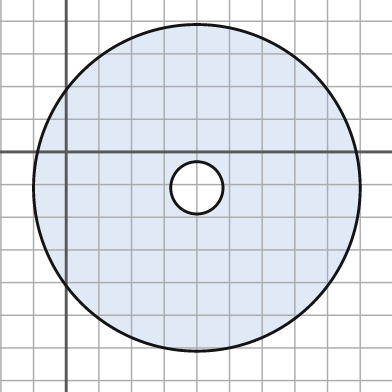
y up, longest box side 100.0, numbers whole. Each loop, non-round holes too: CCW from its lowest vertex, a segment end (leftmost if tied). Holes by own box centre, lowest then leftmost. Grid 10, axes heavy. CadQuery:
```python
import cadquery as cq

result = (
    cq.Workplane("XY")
    .moveTo(40.0, -11.0)
    .circle(50.0)
    .moveTo(40.0, -11.0)
    .circle(8.0)
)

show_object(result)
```